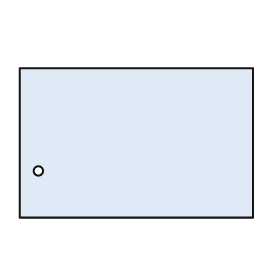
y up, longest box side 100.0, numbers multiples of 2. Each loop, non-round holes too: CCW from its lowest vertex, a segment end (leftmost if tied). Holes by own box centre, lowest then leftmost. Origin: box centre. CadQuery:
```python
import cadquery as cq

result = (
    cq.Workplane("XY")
    .moveTo(-50.0, -32.0)
    .lineTo(50.0, -32.0)
    .lineTo(50.0, 32.0)
    .lineTo(-50.0, 32.0)
    .close()
    .moveTo(-42.0, -12.0)
    .circle(2.0)
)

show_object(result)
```